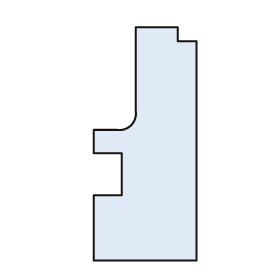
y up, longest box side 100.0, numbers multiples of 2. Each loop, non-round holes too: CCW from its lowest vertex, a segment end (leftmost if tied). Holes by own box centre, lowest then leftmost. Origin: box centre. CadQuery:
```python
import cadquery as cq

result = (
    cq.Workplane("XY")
    .moveTo(-22.0, -50.0)
    .lineTo(22.0, -50.0)
    .lineTo(22.0, 44.0)
    .lineTo(14.0, 44.0)
    .lineTo(14.0, 50.0)
    .lineTo(-4.0, 50.0)
    .lineTo(-4.0, 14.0)
    .threePointArc((-6.0, 8.0), (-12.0, 6.0))
    .lineTo(-22.0, 6.0)
    .lineTo(-22.0, -4.0)
    .lineTo(-10.0, -4.0)
    .lineTo(-10.0, -22.0)
    .lineTo(-22.0, -22.0)
    .close()
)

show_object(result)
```